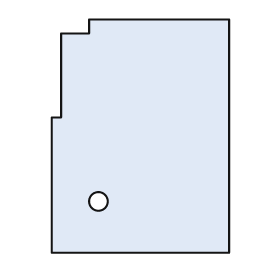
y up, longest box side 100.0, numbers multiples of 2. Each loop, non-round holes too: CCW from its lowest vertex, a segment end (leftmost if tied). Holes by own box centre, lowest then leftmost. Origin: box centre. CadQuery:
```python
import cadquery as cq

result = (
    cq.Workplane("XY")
    .moveTo(-38.0, -50.0)
    .lineTo(38.0, -50.0)
    .lineTo(38.0, 50.0)
    .lineTo(-22.0, 50.0)
    .lineTo(-22.0, 44.0)
    .lineTo(-34.0, 44.0)
    .lineTo(-34.0, 8.0)
    .lineTo(-38.0, 8.0)
    .close()
    .moveTo(-18.0, -28.0)
    .circle(4.0)
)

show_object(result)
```